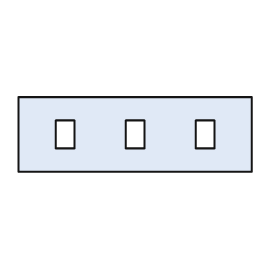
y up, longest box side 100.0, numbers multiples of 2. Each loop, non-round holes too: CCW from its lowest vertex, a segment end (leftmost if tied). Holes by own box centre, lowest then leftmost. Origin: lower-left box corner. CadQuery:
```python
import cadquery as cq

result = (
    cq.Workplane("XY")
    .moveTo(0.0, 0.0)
    .lineTo(100.0, 0.0)
    .lineTo(100.0, 32.0)
    .lineTo(0.0, 32.0)
    .close()
    .moveTo(16.0, 10.0)
    .lineTo(24.0, 10.0)
    .lineTo(24.0, 22.0)
    .lineTo(16.0, 22.0)
    .close()
    .moveTo(46.0, 10.0)
    .lineTo(54.0, 10.0)
    .lineTo(54.0, 22.0)
    .lineTo(46.0, 22.0)
    .close()
    .moveTo(76.0, 10.0)
    .lineTo(84.0, 10.0)
    .lineTo(84.0, 22.0)
    .lineTo(76.0, 22.0)
    .close()
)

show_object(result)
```